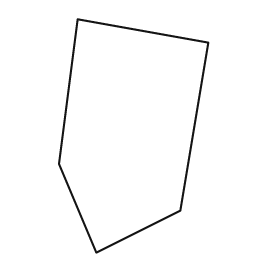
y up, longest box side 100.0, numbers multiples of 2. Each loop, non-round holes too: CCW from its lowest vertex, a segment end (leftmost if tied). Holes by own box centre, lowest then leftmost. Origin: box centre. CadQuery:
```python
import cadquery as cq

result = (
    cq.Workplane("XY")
    .moveTo(-16.0, -50.0)
    .lineTo(20.0, -32.0)
    .lineTo(32.0, 40.0)
    .lineTo(-24.0, 50.0)
    .lineTo(-32.0, -12.0)
    .close()
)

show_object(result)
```